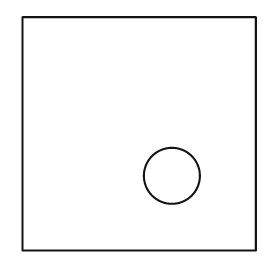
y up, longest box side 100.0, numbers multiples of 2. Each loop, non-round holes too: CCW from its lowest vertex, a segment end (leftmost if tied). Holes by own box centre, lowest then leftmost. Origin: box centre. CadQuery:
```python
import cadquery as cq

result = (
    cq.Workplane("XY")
    .moveTo(-50.0, -50.0)
    .lineTo(50.0, -50.0)
    .lineTo(50.0, 50.0)
    .lineTo(-50.0, 50.0)
    .close()
    .moveTo(14.0, -18.0)
    .circle(12.0)
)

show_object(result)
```